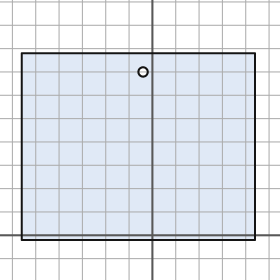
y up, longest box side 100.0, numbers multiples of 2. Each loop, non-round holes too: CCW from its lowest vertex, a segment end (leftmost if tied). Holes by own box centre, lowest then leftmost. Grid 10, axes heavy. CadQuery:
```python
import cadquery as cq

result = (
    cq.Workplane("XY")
    .moveTo(-56.0, -2.0)
    .lineTo(44.0, -2.0)
    .lineTo(44.0, 78.0)
    .lineTo(-56.0, 78.0)
    .close()
    .moveTo(-4.0, 70.0)
    .circle(2.0)
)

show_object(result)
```